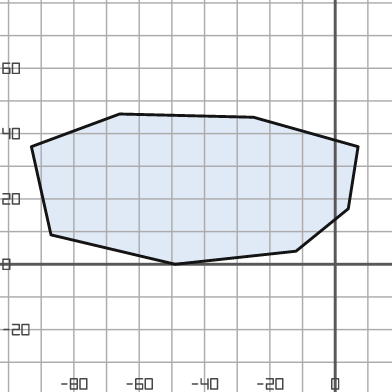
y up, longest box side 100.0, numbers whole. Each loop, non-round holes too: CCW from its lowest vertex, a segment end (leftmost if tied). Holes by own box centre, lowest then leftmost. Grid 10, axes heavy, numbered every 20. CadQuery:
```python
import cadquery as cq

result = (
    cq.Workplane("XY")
    .moveTo(-49.0, 0.0)
    .lineTo(-12.0, 4.0)
    .lineTo(4.0, 17.0)
    .lineTo(7.0, 36.0)
    .lineTo(-25.0, 45.0)
    .lineTo(-66.0, 46.0)
    .lineTo(-93.0, 36.0)
    .lineTo(-87.0, 9.0)
    .close()
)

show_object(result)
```